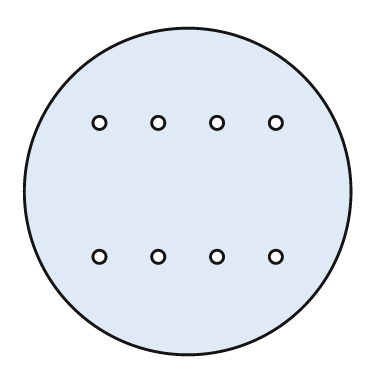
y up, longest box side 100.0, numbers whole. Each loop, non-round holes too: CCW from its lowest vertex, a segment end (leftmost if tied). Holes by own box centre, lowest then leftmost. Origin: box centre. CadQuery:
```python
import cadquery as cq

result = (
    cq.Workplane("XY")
    .moveTo(0.0, 0.0)
    .circle(50.0)
    .moveTo(-27.0, -20.0)
    .circle(2.0)
    .moveTo(-9.0, -20.0)
    .circle(2.0)
    .moveTo(9.0, -20.0)
    .circle(2.0)
    .moveTo(27.0, -20.0)
    .circle(2.0)
    .moveTo(-27.0, 21.0)
    .circle(2.0)
    .moveTo(-9.0, 21.0)
    .circle(2.0)
    .moveTo(9.0, 21.0)
    .circle(2.0)
    .moveTo(27.0, 21.0)
    .circle(2.0)
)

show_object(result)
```